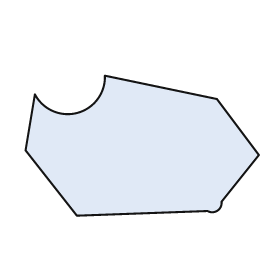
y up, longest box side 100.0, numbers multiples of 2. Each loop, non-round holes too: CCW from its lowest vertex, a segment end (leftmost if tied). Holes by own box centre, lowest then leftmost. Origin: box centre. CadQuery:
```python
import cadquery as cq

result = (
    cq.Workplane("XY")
    .moveTo(-28.0, -30.0)
    .lineTo(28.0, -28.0)
    .threePointArc((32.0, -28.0), (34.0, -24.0))
    .lineTo(50.0, -4.0)
    .lineTo(32.0, 20.0)
    .lineTo(-16.0, 30.0)
    .threePointArc((-28.0, 14.0), (-46.0, 22.0))
    .lineTo(-50.0, -2.0)
    .close()
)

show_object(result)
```